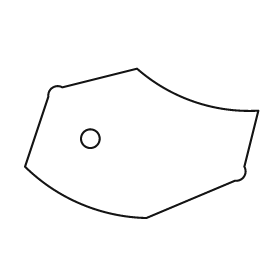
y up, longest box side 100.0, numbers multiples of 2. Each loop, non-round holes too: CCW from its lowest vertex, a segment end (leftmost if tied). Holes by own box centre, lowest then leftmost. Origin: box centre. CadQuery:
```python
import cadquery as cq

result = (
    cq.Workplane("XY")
    .moveTo(2.0, -32.0)
    .lineTo(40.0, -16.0)
    .threePointArc((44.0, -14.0), (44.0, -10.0))
    .lineTo(50.0, 14.0)
    .threePointArc((22.0, 18.0), (-2.0, 32.0))
    .lineTo(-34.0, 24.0)
    .threePointArc((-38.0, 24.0), (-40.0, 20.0))
    .lineTo(-50.0, -10.0)
    .threePointArc((-26.0, -26.0), (2.0, -32.0))
    .close()
    .moveTo(-22.0, 2.0)
    .circle(4.0)
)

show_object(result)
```